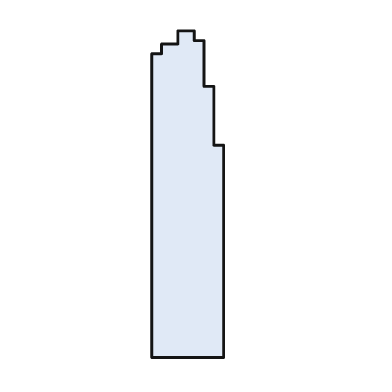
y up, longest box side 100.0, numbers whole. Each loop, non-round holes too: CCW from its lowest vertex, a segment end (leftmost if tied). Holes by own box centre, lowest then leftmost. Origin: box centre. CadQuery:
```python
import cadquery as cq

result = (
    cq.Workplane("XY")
    .moveTo(-11.0, -50.0)
    .lineTo(11.0, -50.0)
    .lineTo(11.0, 15.0)
    .lineTo(8.0, 15.0)
    .lineTo(8.0, 33.0)
    .lineTo(5.0, 33.0)
    .lineTo(5.0, 47.0)
    .lineTo(2.0, 47.0)
    .lineTo(2.0, 50.0)
    .lineTo(-3.0, 50.0)
    .lineTo(-3.0, 46.0)
    .lineTo(-8.0, 46.0)
    .lineTo(-8.0, 43.0)
    .lineTo(-11.0, 43.0)
    .close()
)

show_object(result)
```